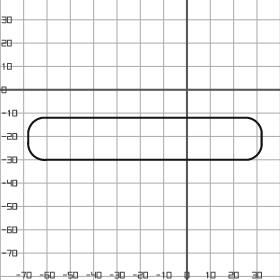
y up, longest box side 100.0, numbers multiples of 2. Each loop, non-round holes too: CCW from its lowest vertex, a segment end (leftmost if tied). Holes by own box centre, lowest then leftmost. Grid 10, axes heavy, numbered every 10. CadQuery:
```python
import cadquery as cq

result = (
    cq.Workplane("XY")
    .moveTo(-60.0, -30.0)
    .lineTo(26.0, -30.0)
    .threePointArc((30.0, -28.0), (32.0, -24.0))
    .lineTo(32.0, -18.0)
    .threePointArc((30.0, -14.0), (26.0, -12.0))
    .lineTo(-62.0, -12.0)
    .threePointArc((-66.0, -14.0), (-68.0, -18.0))
    .lineTo(-68.0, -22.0)
    .threePointArc((-66.0, -28.0), (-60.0, -30.0))
    .close()
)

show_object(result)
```